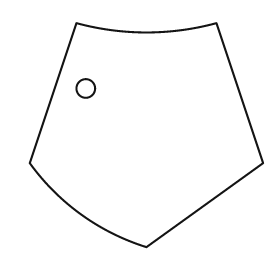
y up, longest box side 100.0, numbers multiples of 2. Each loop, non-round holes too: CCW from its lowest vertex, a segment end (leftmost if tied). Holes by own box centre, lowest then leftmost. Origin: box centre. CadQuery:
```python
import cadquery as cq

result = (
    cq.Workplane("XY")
    .moveTo(0.0, -48.0)
    .lineTo(50.0, -12.0)
    .lineTo(30.0, 48.0)
    .threePointArc((0.0, 44.0), (-30.0, 48.0))
    .lineTo(-50.0, -12.0)
    .threePointArc((-28.0, -34.0), (0.0, -48.0))
    .close()
    .moveTo(-26.0, 20.0)
    .circle(4.0)
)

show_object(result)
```